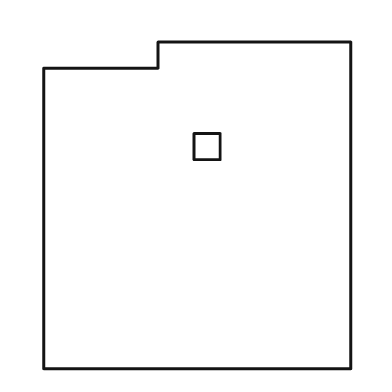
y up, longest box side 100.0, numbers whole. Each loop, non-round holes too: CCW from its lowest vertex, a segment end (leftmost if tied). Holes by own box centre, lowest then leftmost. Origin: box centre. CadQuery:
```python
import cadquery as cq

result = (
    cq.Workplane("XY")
    .moveTo(-47.0, -50.0)
    .lineTo(47.0, -50.0)
    .lineTo(47.0, 50.0)
    .lineTo(-12.0, 50.0)
    .lineTo(-12.0, 42.0)
    .lineTo(-47.0, 42.0)
    .close()
    .moveTo(-1.0, 14.0)
    .lineTo(7.0, 14.0)
    .lineTo(7.0, 22.0)
    .lineTo(-1.0, 22.0)
    .close()
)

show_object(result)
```